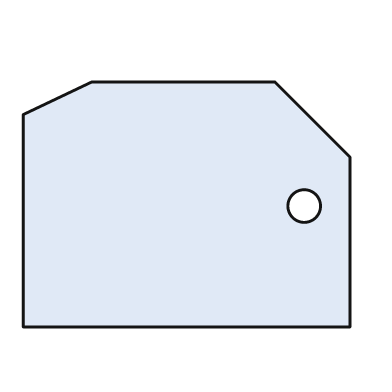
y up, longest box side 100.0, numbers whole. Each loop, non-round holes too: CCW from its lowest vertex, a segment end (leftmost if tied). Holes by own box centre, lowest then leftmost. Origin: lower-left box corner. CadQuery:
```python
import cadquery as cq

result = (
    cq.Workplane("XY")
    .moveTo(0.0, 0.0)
    .lineTo(100.0, 0.0)
    .lineTo(100.0, 52.0)
    .lineTo(77.0, 75.0)
    .lineTo(21.0, 75.0)
    .lineTo(0.0, 65.0)
    .close()
    .moveTo(86.0, 37.0)
    .circle(5.0)
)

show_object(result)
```